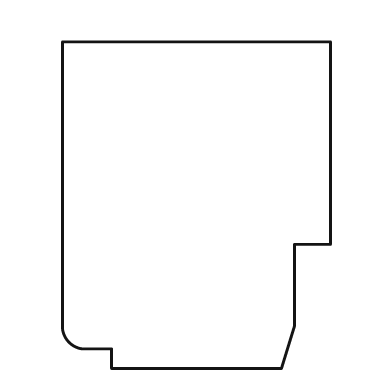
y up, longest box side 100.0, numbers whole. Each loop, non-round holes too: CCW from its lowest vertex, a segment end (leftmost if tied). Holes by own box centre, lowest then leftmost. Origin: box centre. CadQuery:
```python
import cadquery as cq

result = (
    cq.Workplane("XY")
    .moveTo(-26.0, -50.0)
    .lineTo(26.0, -50.0)
    .lineTo(30.0, -37.0)
    .lineTo(30.0, -12.0)
    .lineTo(41.0, -12.0)
    .lineTo(41.0, 50.0)
    .lineTo(-41.0, 50.0)
    .lineTo(-41.0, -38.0)
    .threePointArc((-39.0, -42.0), (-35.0, -44.0))
    .lineTo(-26.0, -44.0)
    .close()
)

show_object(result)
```